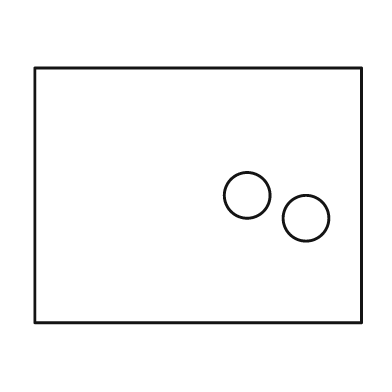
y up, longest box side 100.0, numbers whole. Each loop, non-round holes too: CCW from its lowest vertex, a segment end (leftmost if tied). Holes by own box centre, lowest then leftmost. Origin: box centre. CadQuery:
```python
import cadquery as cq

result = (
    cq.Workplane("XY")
    .moveTo(-50.0, -39.0)
    .lineTo(50.0, -39.0)
    .lineTo(50.0, 39.0)
    .lineTo(-50.0, 39.0)
    .close()
    .moveTo(33.0, -7.0)
    .circle(7.0)
    .moveTo(15.0, 0.0)
    .circle(7.0)
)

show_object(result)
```